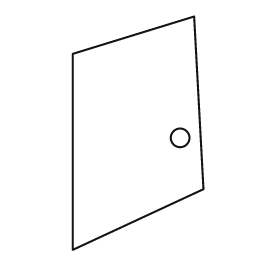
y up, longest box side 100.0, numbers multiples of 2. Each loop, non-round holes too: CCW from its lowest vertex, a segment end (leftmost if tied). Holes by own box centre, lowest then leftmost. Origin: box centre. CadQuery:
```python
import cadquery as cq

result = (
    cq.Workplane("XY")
    .moveTo(-28.0, -50.0)
    .lineTo(28.0, -24.0)
    .lineTo(24.0, 50.0)
    .lineTo(-28.0, 34.0)
    .close()
    .moveTo(18.0, -2.0)
    .circle(4.0)
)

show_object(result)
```